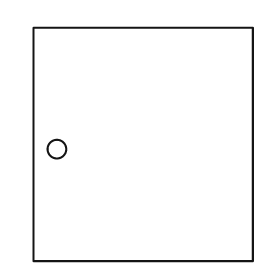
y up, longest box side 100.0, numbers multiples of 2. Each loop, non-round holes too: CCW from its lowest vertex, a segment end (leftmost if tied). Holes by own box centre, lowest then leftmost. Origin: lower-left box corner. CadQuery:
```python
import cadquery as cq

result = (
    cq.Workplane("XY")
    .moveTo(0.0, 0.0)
    .lineTo(94.0, 0.0)
    .lineTo(94.0, 100.0)
    .lineTo(0.0, 100.0)
    .close()
    .moveTo(10.0, 48.0)
    .circle(4.0)
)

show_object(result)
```